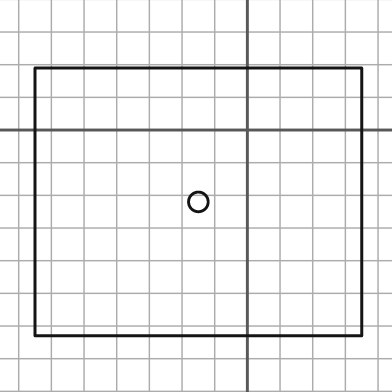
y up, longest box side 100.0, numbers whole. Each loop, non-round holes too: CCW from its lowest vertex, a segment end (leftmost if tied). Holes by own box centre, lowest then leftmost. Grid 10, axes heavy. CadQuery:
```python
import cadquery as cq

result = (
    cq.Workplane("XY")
    .moveTo(-65.0, -63.0)
    .lineTo(35.0, -63.0)
    .lineTo(35.0, 19.0)
    .lineTo(-65.0, 19.0)
    .close()
    .moveTo(-15.0, -22.0)
    .circle(3.0)
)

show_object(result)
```